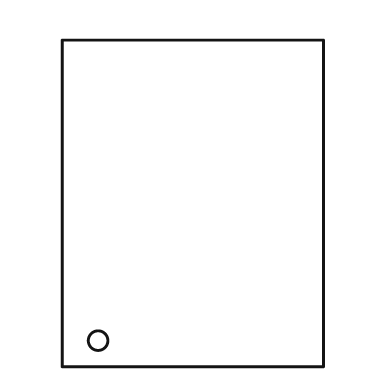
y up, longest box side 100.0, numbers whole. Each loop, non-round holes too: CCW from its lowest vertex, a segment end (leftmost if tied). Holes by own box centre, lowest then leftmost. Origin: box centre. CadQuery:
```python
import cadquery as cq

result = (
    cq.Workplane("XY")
    .moveTo(-40.0, -50.0)
    .lineTo(40.0, -50.0)
    .lineTo(40.0, 50.0)
    .lineTo(-40.0, 50.0)
    .close()
    .moveTo(-29.0, -42.0)
    .circle(3.0)
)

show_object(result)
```